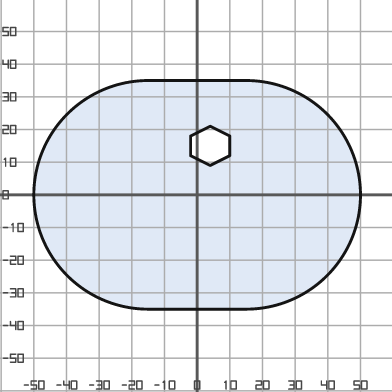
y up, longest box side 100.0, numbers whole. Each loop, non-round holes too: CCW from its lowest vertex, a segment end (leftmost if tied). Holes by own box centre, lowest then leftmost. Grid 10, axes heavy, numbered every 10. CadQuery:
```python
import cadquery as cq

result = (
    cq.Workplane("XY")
    .moveTo(-15.0, -35.0)
    .lineTo(15.0, -35.0)
    .threePointArc((50.0, 0.0), (15.0, 35.0))
    .lineTo(-15.0, 35.0)
    .threePointArc((-50.0, 0.0), (-15.0, -35.0))
    .close()
    .moveTo(4.0, 9.0)
    .lineTo(10.0, 12.0)
    .lineTo(10.0, 18.0)
    .lineTo(4.0, 21.0)
    .lineTo(-2.0, 18.0)
    .lineTo(-2.0, 12.0)
    .close()
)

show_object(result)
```